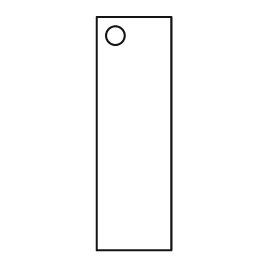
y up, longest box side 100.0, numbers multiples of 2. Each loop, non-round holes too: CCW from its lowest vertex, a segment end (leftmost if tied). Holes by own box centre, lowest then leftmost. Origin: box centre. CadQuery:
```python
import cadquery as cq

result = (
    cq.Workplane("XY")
    .moveTo(-16.0, -50.0)
    .lineTo(16.0, -50.0)
    .lineTo(16.0, 50.0)
    .lineTo(-16.0, 50.0)
    .close()
    .moveTo(-8.0, 42.0)
    .circle(4.0)
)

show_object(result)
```